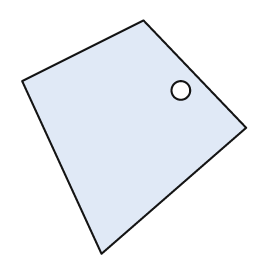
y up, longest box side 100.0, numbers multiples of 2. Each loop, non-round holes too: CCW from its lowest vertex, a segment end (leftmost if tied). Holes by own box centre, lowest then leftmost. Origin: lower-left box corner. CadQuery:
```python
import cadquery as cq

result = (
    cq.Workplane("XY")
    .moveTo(34.0, 0.0)
    .lineTo(96.0, 54.0)
    .lineTo(52.0, 100.0)
    .lineTo(0.0, 74.0)
    .close()
    .moveTo(68.0, 70.0)
    .circle(4.0)
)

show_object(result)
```